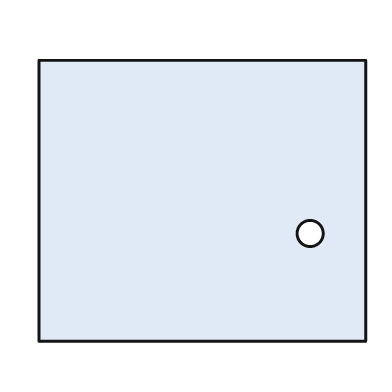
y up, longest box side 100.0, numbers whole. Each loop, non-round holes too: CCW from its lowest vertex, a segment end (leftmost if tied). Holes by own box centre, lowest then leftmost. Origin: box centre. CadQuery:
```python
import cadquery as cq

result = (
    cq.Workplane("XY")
    .moveTo(-50.0, -43.0)
    .lineTo(50.0, -43.0)
    .lineTo(50.0, 43.0)
    .lineTo(-50.0, 43.0)
    .close()
    .moveTo(33.0, -10.0)
    .circle(4.0)
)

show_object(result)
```